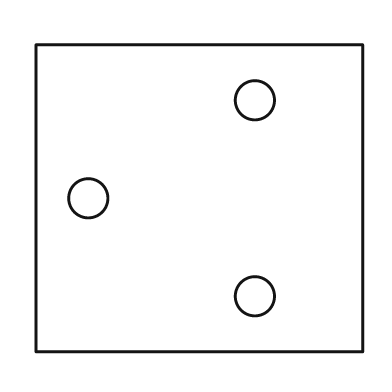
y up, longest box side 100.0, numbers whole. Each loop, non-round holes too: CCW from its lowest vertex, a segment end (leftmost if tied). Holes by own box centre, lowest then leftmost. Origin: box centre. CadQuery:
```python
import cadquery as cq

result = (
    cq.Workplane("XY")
    .moveTo(-50.0, -47.0)
    .lineTo(50.0, -47.0)
    .lineTo(50.0, 47.0)
    .lineTo(-50.0, 47.0)
    .close()
    .moveTo(17.0, -30.0)
    .circle(6.0)
    .moveTo(-34.0, 0.0)
    .circle(6.0)
    .moveTo(17.0, 30.0)
    .circle(6.0)
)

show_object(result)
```